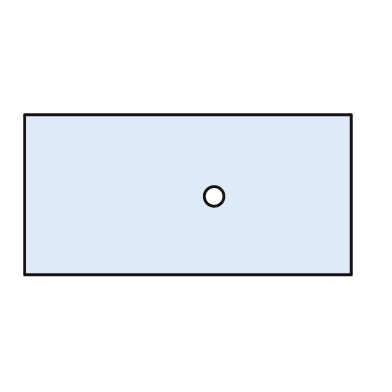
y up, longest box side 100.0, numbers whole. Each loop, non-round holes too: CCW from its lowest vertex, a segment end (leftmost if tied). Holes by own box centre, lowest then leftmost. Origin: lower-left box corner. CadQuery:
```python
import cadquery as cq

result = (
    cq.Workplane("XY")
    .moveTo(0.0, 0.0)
    .lineTo(100.0, 0.0)
    .lineTo(100.0, 49.0)
    .lineTo(0.0, 49.0)
    .close()
    .moveTo(58.0, 24.0)
    .circle(3.0)
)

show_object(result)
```